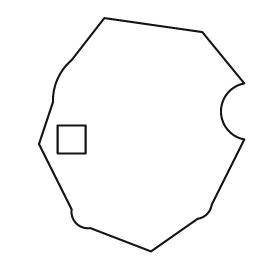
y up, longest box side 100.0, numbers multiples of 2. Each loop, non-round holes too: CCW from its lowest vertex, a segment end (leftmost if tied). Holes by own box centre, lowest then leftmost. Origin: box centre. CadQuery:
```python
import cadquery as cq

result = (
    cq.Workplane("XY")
    .moveTo(4.0, -50.0)
    .lineTo(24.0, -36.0)
    .threePointArc((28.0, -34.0), (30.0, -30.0))
    .lineTo(44.0, -2.0)
    .threePointArc((34.0, 10.0), (44.0, 22.0))
    .lineTo(26.0, 44.0)
    .lineTo(-16.0, 50.0)
    .lineTo(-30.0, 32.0)
    .threePointArc((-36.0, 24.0), (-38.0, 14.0))
    .lineTo(-44.0, -4.0)
    .lineTo(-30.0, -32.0)
    .threePointArc((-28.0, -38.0), (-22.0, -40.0))
    .close()
    .moveTo(-36.0, -8.0)
    .lineTo(-24.0, -8.0)
    .lineTo(-24.0, 4.0)
    .lineTo(-36.0, 4.0)
    .close()
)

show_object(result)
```